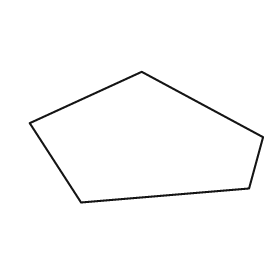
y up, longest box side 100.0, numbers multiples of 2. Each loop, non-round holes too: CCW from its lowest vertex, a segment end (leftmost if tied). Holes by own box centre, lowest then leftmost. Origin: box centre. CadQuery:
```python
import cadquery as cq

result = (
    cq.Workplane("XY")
    .moveTo(-28.0, -28.0)
    .lineTo(44.0, -22.0)
    .lineTo(50.0, 0.0)
    .lineTo(-2.0, 28.0)
    .lineTo(-50.0, 6.0)
    .close()
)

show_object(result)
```